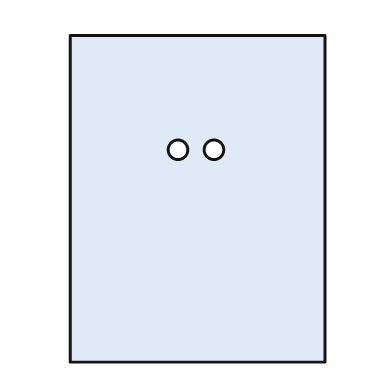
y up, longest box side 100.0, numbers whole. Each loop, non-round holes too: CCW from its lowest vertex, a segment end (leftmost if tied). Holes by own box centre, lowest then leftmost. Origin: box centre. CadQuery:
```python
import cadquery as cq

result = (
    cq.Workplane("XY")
    .moveTo(-39.0, -50.0)
    .lineTo(39.0, -50.0)
    .lineTo(39.0, 50.0)
    .lineTo(-39.0, 50.0)
    .close()
    .moveTo(-6.0, 15.0)
    .circle(3.0)
    .moveTo(5.0, 15.0)
    .circle(3.0)
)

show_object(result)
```